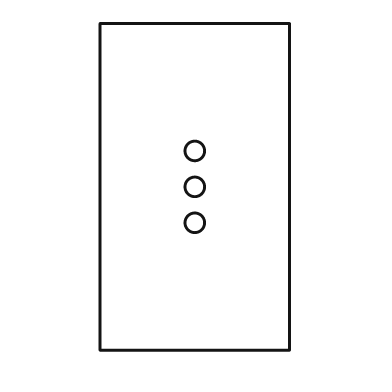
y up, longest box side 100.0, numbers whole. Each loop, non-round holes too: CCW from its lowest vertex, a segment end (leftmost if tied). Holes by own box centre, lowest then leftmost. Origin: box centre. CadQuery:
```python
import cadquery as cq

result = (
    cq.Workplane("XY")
    .moveTo(-29.0, -50.0)
    .lineTo(29.0, -50.0)
    .lineTo(29.0, 50.0)
    .lineTo(-29.0, 50.0)
    .close()
    .moveTo(0.0, -11.0)
    .circle(3.0)
    .moveTo(0.0, 0.0)
    .circle(3.0)
    .moveTo(0.0, 11.0)
    .circle(3.0)
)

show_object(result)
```